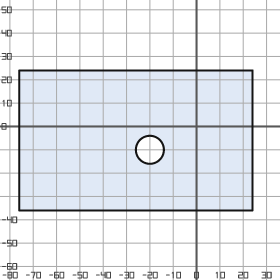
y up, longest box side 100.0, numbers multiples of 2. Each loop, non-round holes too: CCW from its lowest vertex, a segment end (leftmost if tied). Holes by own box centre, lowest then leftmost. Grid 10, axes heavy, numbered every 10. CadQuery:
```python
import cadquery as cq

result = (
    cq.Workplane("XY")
    .moveTo(-76.0, -36.0)
    .lineTo(24.0, -36.0)
    .lineTo(24.0, 24.0)
    .lineTo(-76.0, 24.0)
    .close()
    .moveTo(-20.0, -10.0)
    .circle(6.0)
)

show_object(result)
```